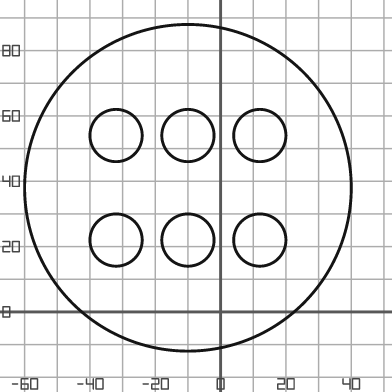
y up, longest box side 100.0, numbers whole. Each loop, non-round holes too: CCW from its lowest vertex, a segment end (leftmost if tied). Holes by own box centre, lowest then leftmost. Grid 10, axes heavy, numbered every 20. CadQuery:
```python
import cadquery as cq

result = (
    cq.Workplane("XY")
    .moveTo(-10.0, 38.0)
    .circle(50.0)
    .moveTo(-32.0, 22.0)
    .circle(8.0)
    .moveTo(-10.0, 22.0)
    .circle(8.0)
    .moveTo(12.0, 22.0)
    .circle(8.0)
    .moveTo(-32.0, 54.0)
    .circle(8.0)
    .moveTo(-10.0, 54.0)
    .circle(8.0)
    .moveTo(12.0, 54.0)
    .circle(8.0)
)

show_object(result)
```